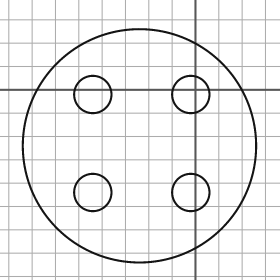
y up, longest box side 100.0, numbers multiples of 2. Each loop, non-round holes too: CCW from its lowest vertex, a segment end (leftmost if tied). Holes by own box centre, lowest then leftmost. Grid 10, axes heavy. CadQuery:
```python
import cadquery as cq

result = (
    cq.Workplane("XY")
    .moveTo(-24.0, -24.0)
    .circle(50.0)
    .moveTo(-44.0, -44.0)
    .circle(8.0)
    .moveTo(-2.0, -44.0)
    .circle(8.0)
    .moveTo(-44.0, -2.0)
    .circle(8.0)
    .moveTo(-2.0, -2.0)
    .circle(8.0)
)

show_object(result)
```